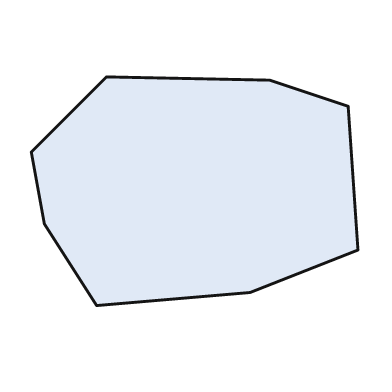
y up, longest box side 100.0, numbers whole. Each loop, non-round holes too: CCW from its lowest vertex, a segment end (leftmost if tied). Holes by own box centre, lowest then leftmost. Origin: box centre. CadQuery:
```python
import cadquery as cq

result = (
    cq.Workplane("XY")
    .moveTo(-30.0, -35.0)
    .lineTo(17.0, -31.0)
    .lineTo(50.0, -18.0)
    .lineTo(47.0, 26.0)
    .lineTo(23.0, 34.0)
    .lineTo(-27.0, 35.0)
    .lineTo(-50.0, 12.0)
    .lineTo(-46.0, -10.0)
    .close()
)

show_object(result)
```